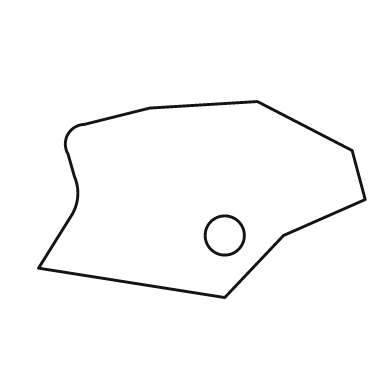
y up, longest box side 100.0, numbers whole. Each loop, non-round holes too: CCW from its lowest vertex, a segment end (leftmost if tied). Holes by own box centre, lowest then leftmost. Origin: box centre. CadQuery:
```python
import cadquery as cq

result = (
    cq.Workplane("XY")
    .moveTo(7.0, -30.0)
    .lineTo(25.0, -11.0)
    .lineTo(50.0, 0.0)
    .lineTo(46.0, 15.0)
    .lineTo(17.0, 30.0)
    .lineTo(-16.0, 28.0)
    .lineTo(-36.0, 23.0)
    .threePointArc((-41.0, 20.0), (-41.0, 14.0))
    .lineTo(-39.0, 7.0)
    .threePointArc((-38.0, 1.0), (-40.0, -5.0))
    .lineTo(-50.0, -21.0)
    .close()
    .moveTo(7.0, -11.0)
    .circle(6.0)
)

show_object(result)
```